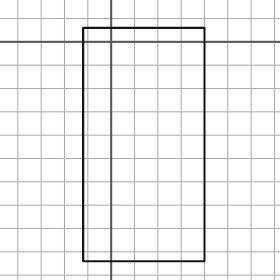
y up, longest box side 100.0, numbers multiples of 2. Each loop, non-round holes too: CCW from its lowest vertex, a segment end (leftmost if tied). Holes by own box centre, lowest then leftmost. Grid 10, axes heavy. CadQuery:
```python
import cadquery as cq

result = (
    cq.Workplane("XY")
    .moveTo(-12.0, -94.0)
    .lineTo(40.0, -94.0)
    .lineTo(40.0, 6.0)
    .lineTo(-12.0, 6.0)
    .close()
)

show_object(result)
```